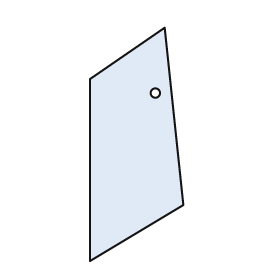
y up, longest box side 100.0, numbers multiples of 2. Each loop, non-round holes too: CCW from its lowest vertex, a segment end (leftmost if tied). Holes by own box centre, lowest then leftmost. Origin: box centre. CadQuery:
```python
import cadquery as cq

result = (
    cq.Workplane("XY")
    .moveTo(-20.0, -50.0)
    .lineTo(20.0, -26.0)
    .lineTo(12.0, 50.0)
    .lineTo(-20.0, 28.0)
    .close()
    .moveTo(8.0, 22.0)
    .circle(2.0)
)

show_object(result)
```